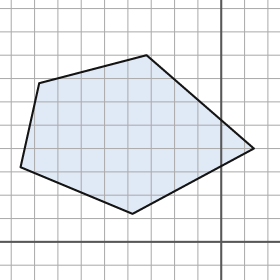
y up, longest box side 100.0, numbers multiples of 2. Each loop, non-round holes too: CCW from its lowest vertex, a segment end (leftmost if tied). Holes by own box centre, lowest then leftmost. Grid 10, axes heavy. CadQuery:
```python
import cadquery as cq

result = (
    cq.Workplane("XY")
    .moveTo(-38.0, 12.0)
    .lineTo(14.0, 40.0)
    .lineTo(-32.0, 80.0)
    .lineTo(-78.0, 68.0)
    .lineTo(-86.0, 32.0)
    .close()
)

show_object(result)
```